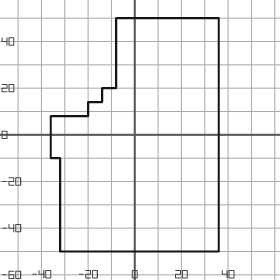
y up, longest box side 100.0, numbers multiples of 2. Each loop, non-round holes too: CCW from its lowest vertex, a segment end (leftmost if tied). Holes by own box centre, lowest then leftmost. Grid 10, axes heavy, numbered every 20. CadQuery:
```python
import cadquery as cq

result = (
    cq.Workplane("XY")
    .moveTo(-32.0, -50.0)
    .lineTo(36.0, -50.0)
    .lineTo(36.0, 50.0)
    .lineTo(-8.0, 50.0)
    .lineTo(-8.0, 20.0)
    .lineTo(-14.0, 20.0)
    .lineTo(-14.0, 14.0)
    .lineTo(-20.0, 14.0)
    .lineTo(-20.0, 8.0)
    .lineTo(-36.0, 8.0)
    .lineTo(-36.0, -10.0)
    .lineTo(-32.0, -10.0)
    .close()
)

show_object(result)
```